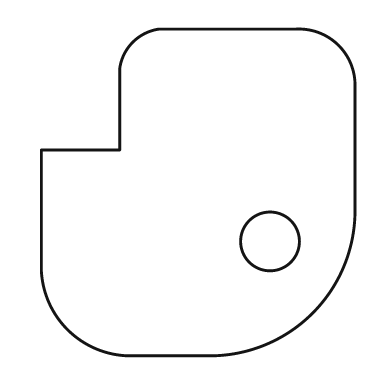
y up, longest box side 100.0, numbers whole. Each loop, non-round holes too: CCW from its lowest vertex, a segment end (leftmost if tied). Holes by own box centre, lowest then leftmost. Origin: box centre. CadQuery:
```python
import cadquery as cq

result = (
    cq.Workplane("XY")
    .moveTo(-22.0, -50.0)
    .lineTo(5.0, -50.0)
    .threePointArc((35.0, -37.0), (48.0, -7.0))
    .lineTo(48.0, 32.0)
    .threePointArc((43.0, 45.0), (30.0, 50.0))
    .lineTo(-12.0, 50.0)
    .threePointArc((-20.0, 46.0), (-24.0, 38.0))
    .lineTo(-24.0, 13.0)
    .lineTo(-48.0, 13.0)
    .lineTo(-48.0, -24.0)
    .threePointArc((-40.0, -42.0), (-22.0, -50.0))
    .close()
    .moveTo(22.0, -15.0)
    .circle(9.0)
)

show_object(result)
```